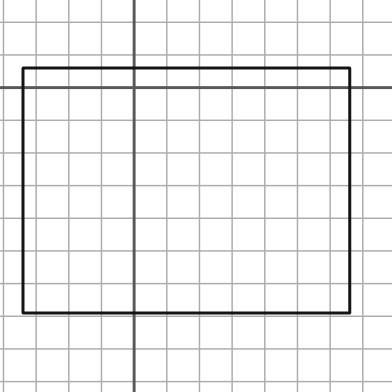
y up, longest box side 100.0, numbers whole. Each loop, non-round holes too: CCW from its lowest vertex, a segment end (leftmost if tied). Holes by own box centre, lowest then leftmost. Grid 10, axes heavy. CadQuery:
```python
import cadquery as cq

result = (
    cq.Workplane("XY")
    .moveTo(-34.0, -69.0)
    .lineTo(66.0, -69.0)
    .lineTo(66.0, 6.0)
    .lineTo(-34.0, 6.0)
    .close()
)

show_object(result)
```